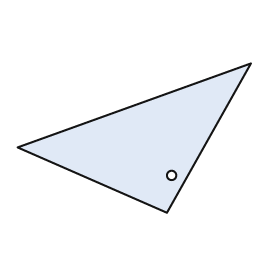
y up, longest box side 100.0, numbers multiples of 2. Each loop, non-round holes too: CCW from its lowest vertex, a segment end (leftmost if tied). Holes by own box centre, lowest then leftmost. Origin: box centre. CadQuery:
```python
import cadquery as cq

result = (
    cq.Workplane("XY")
    .moveTo(14.0, -32.0)
    .lineTo(50.0, 32.0)
    .lineTo(-50.0, -4.0)
    .close()
    .moveTo(16.0, -16.0)
    .circle(2.0)
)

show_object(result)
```